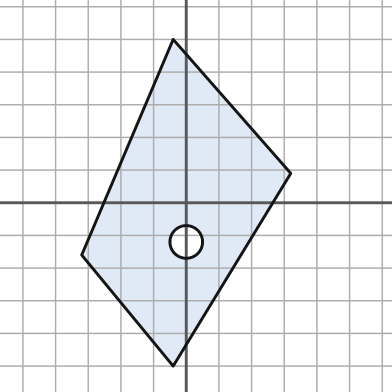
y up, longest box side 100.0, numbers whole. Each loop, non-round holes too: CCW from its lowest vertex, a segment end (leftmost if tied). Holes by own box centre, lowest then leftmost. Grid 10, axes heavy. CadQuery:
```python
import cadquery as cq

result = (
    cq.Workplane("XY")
    .moveTo(-4.0, -50.0)
    .lineTo(32.0, 9.0)
    .lineTo(-4.0, 50.0)
    .lineTo(-32.0, -16.0)
    .close()
    .moveTo(0.0, -12.0)
    .circle(5.0)
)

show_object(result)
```